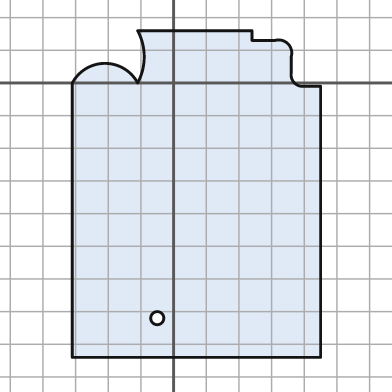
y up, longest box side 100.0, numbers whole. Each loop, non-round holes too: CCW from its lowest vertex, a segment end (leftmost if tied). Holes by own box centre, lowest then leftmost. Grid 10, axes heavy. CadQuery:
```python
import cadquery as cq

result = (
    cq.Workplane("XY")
    .moveTo(-31.0, -84.0)
    .lineTo(45.0, -84.0)
    .lineTo(45.0, -1.0)
    .lineTo(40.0, -1.0)
    .threePointArc((37.0, 0.0), (36.0, 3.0))
    .lineTo(36.0, 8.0)
    .threePointArc((35.0, 12.0), (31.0, 13.0))
    .lineTo(24.0, 13.0)
    .lineTo(24.0, 16.0)
    .lineTo(-11.0, 16.0)
    .threePointArc((-9.0, 8.0), (-11.0, 0.0))
    .threePointArc((-21.0, 6.0), (-31.0, 0.0))
    .close()
    .moveTo(-5.0, -72.0)
    .circle(2.0)
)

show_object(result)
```